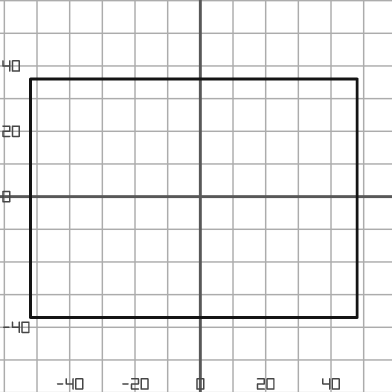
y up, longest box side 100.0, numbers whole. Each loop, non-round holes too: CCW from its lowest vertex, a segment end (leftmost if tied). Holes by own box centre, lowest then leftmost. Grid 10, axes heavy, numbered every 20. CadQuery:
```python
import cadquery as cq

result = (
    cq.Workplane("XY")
    .moveTo(-52.0, -37.0)
    .lineTo(48.0, -37.0)
    .lineTo(48.0, 36.0)
    .lineTo(-52.0, 36.0)
    .close()
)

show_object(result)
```